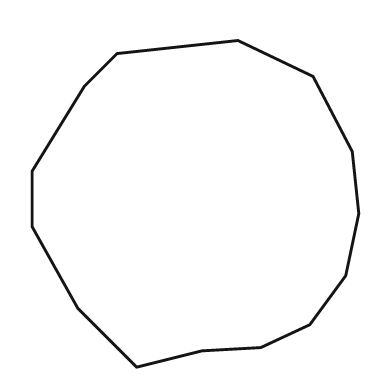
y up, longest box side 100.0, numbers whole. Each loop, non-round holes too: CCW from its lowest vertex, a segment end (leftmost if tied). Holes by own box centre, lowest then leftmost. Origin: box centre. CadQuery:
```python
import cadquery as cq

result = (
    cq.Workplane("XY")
    .moveTo(-18.0, -50.0)
    .lineTo(2.0, -45.0)
    .lineTo(20.0, -44.0)
    .lineTo(35.0, -37.0)
    .lineTo(46.0, -22.0)
    .lineTo(50.0, -3.0)
    .lineTo(48.0, 16.0)
    .lineTo(36.0, 39.0)
    .lineTo(13.0, 50.0)
    .lineTo(-24.0, 46.0)
    .lineTo(-34.0, 36.0)
    .lineTo(-50.0, 10.0)
    .lineTo(-50.0, -7.0)
    .lineTo(-36.0, -32.0)
    .close()
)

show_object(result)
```